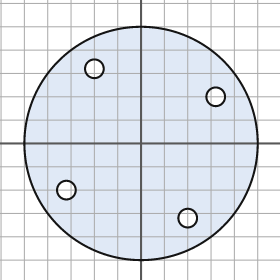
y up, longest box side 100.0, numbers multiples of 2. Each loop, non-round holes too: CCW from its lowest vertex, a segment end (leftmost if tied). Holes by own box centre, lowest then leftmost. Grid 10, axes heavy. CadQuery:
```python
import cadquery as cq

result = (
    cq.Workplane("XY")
    .moveTo(0.0, 0.0)
    .circle(50.0)
    .moveTo(20.0, -32.0)
    .circle(4.0)
    .moveTo(-32.0, -20.0)
    .circle(4.0)
    .moveTo(32.0, 20.0)
    .circle(4.0)
    .moveTo(-20.0, 32.0)
    .circle(4.0)
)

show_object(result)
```